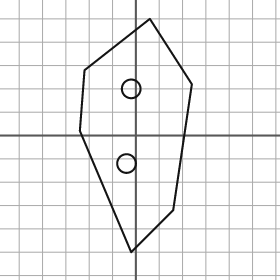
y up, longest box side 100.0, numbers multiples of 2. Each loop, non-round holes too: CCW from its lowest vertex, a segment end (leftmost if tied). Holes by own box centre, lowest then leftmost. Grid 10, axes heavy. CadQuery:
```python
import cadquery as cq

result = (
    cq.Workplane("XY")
    .moveTo(-2.0, -50.0)
    .lineTo(16.0, -32.0)
    .lineTo(24.0, 22.0)
    .lineTo(6.0, 50.0)
    .lineTo(-22.0, 28.0)
    .lineTo(-24.0, 2.0)
    .close()
    .moveTo(-4.0, -12.0)
    .circle(4.0)
    .moveTo(-2.0, 20.0)
    .circle(4.0)
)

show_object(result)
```